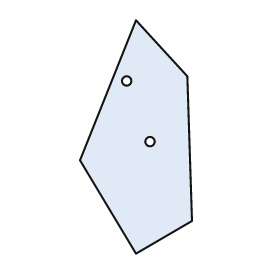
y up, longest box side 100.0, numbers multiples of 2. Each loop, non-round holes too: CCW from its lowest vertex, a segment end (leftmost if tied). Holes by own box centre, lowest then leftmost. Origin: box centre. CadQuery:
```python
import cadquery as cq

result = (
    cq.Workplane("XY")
    .moveTo(0.0, -50.0)
    .lineTo(24.0, -36.0)
    .lineTo(22.0, 26.0)
    .lineTo(0.0, 50.0)
    .lineTo(-24.0, -10.0)
    .close()
    .moveTo(6.0, -2.0)
    .circle(2.0)
    .moveTo(-4.0, 24.0)
    .circle(2.0)
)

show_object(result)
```